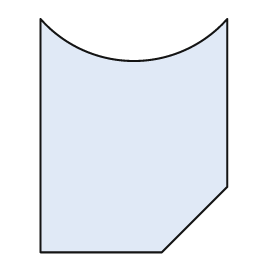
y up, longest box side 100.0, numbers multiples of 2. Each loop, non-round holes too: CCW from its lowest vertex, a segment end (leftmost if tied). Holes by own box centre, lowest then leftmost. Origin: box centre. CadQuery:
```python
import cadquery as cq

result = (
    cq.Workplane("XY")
    .moveTo(-40.0, -50.0)
    .lineTo(12.0, -50.0)
    .lineTo(40.0, -22.0)
    .lineTo(40.0, 50.0)
    .threePointArc((0.0, 32.0), (-40.0, 50.0))
    .close()
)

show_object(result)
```